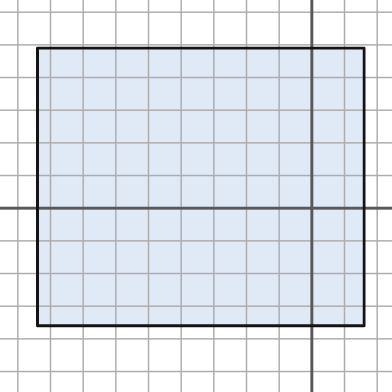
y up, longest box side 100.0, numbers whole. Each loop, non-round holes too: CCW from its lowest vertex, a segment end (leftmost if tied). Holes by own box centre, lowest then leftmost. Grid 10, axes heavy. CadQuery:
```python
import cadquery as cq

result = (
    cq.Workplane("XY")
    .moveTo(-84.0, -36.0)
    .lineTo(16.0, -36.0)
    .lineTo(16.0, 49.0)
    .lineTo(-84.0, 49.0)
    .close()
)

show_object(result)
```